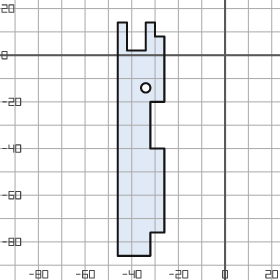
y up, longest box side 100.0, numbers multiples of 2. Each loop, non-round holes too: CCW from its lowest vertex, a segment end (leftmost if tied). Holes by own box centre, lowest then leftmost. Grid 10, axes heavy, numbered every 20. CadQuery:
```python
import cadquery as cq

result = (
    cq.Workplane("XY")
    .moveTo(-46.0, -86.0)
    .lineTo(-32.0, -86.0)
    .lineTo(-32.0, -76.0)
    .lineTo(-26.0, -76.0)
    .lineTo(-26.0, -40.0)
    .lineTo(-32.0, -40.0)
    .lineTo(-32.0, -20.0)
    .lineTo(-26.0, -20.0)
    .lineTo(-26.0, 8.0)
    .lineTo(-30.0, 8.0)
    .lineTo(-30.0, 14.0)
    .lineTo(-34.0, 14.0)
    .lineTo(-34.0, 2.0)
    .lineTo(-42.0, 2.0)
    .lineTo(-42.0, 14.0)
    .lineTo(-46.0, 14.0)
    .close()
    .moveTo(-34.0, -14.0)
    .circle(2.0)
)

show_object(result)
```